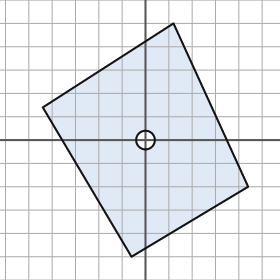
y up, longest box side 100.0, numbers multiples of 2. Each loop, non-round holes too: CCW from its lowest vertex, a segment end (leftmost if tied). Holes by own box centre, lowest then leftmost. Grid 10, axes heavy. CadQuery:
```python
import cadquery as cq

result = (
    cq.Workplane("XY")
    .moveTo(-6.0, -50.0)
    .lineTo(44.0, -20.0)
    .lineTo(12.0, 50.0)
    .lineTo(-44.0, 14.0)
    .close()
    .moveTo(0.0, 0.0)
    .circle(4.0)
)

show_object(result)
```